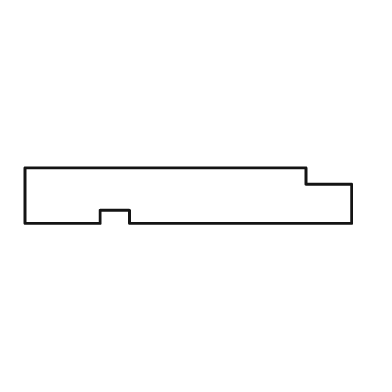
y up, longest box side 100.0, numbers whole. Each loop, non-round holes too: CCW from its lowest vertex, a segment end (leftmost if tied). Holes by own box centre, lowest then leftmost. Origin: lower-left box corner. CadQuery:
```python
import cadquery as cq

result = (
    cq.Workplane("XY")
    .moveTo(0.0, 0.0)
    .lineTo(23.0, 0.0)
    .lineTo(23.0, 4.0)
    .lineTo(32.0, 4.0)
    .lineTo(32.0, 0.0)
    .lineTo(100.0, 0.0)
    .lineTo(100.0, 12.0)
    .lineTo(86.0, 12.0)
    .lineTo(86.0, 17.0)
    .lineTo(0.0, 17.0)
    .close()
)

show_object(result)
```